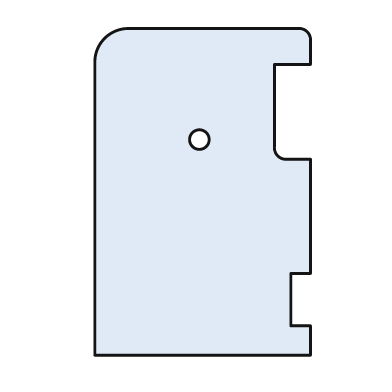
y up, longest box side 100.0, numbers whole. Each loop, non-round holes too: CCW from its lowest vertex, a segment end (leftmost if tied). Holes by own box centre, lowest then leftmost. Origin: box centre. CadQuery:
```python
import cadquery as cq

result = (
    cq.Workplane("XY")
    .moveTo(-33.0, -50.0)
    .lineTo(33.0, -50.0)
    .lineTo(33.0, -41.0)
    .lineTo(27.0, -41.0)
    .lineTo(27.0, -25.0)
    .lineTo(33.0, -25.0)
    .lineTo(33.0, 10.0)
    .lineTo(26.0, 10.0)
    .threePointArc((23.0, 11.0), (22.0, 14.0))
    .lineTo(22.0, 39.0)
    .lineTo(33.0, 39.0)
    .lineTo(33.0, 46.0)
    .threePointArc((32.0, 49.0), (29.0, 50.0))
    .lineTo(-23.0, 50.0)
    .threePointArc((-30.0, 47.0), (-33.0, 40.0))
    .close()
    .moveTo(-1.0, 16.0)
    .circle(3.0)
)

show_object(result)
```